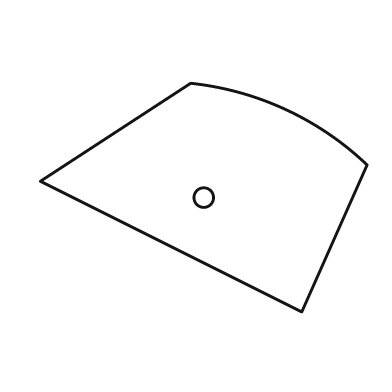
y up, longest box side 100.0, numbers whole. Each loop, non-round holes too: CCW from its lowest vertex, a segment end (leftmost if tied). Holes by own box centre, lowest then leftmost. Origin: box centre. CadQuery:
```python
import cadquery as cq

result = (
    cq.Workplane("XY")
    .moveTo(30.0, -35.0)
    .lineTo(50.0, 10.0)
    .threePointArc((25.0, 27.0), (-4.0, 35.0))
    .lineTo(-50.0, 5.0)
    .close()
    .moveTo(0.0, 0.0)
    .circle(3.0)
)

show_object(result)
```